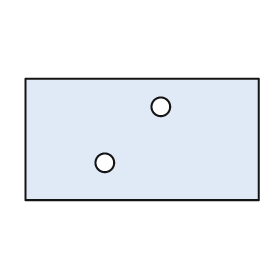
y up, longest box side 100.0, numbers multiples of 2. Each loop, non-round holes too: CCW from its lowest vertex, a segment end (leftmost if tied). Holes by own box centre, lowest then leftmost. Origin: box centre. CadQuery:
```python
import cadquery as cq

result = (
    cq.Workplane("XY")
    .moveTo(-50.0, -26.0)
    .lineTo(50.0, -26.0)
    .lineTo(50.0, 26.0)
    .lineTo(-50.0, 26.0)
    .close()
    .moveTo(-16.0, -10.0)
    .circle(4.0)
    .moveTo(8.0, 14.0)
    .circle(4.0)
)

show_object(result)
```